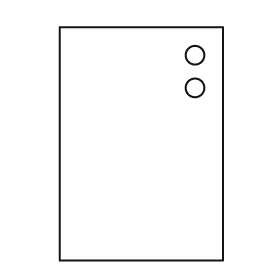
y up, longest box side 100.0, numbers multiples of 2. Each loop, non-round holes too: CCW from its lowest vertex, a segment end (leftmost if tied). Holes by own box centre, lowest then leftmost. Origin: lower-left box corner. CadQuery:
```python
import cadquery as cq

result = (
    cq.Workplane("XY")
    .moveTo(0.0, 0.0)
    .lineTo(70.0, 0.0)
    .lineTo(70.0, 100.0)
    .lineTo(0.0, 100.0)
    .close()
    .moveTo(58.0, 74.0)
    .circle(4.0)
    .moveTo(58.0, 88.0)
    .circle(4.0)
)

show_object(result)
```